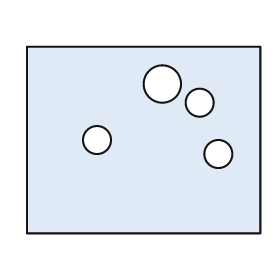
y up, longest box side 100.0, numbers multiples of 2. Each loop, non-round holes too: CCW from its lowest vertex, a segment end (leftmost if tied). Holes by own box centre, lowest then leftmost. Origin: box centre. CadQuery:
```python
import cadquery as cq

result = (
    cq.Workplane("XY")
    .moveTo(-50.0, -40.0)
    .lineTo(50.0, -40.0)
    .lineTo(50.0, 40.0)
    .lineTo(-50.0, 40.0)
    .close()
    .moveTo(32.0, -6.0)
    .circle(6.0)
    .moveTo(-20.0, 0.0)
    .circle(6.0)
    .moveTo(24.0, 16.0)
    .circle(6.0)
    .moveTo(8.0, 24.0)
    .circle(8.0)
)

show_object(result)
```